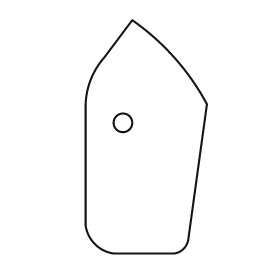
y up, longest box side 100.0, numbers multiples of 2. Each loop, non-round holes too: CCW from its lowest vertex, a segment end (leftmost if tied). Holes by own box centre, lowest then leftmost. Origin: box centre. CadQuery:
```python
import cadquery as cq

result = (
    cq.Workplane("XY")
    .moveTo(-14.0, -50.0)
    .lineTo(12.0, -50.0)
    .threePointArc((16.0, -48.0), (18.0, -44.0))
    .lineTo(26.0, 14.0)
    .threePointArc((12.0, 34.0), (-6.0, 50.0))
    .lineTo(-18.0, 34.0)
    .threePointArc((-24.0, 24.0), (-26.0, 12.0))
    .lineTo(-26.0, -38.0)
    .threePointArc((-22.0, -46.0), (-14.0, -50.0))
    .close()
    .moveTo(-10.0, 6.0)
    .circle(4.0)
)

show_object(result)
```